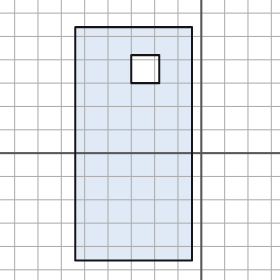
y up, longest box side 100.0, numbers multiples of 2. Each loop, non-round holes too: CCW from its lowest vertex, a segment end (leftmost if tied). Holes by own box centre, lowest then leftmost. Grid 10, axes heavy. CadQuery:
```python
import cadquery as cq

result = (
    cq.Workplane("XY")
    .moveTo(-54.0, -46.0)
    .lineTo(-4.0, -46.0)
    .lineTo(-4.0, 54.0)
    .lineTo(-54.0, 54.0)
    .close()
    .moveTo(-30.0, 30.0)
    .lineTo(-18.0, 30.0)
    .lineTo(-18.0, 42.0)
    .lineTo(-30.0, 42.0)
    .close()
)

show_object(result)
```